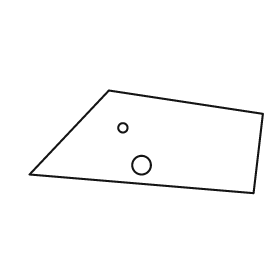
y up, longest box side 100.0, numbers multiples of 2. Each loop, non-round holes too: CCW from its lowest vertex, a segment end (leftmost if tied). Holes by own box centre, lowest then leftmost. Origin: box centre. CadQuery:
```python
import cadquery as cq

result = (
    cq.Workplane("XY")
    .moveTo(46.0, -22.0)
    .lineTo(50.0, 12.0)
    .lineTo(-16.0, 22.0)
    .lineTo(-50.0, -14.0)
    .close()
    .moveTo(-2.0, -10.0)
    .circle(4.0)
    .moveTo(-10.0, 6.0)
    .circle(2.0)
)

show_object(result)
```